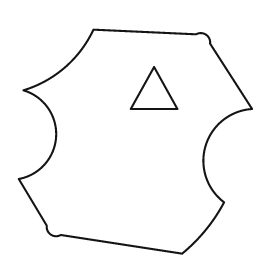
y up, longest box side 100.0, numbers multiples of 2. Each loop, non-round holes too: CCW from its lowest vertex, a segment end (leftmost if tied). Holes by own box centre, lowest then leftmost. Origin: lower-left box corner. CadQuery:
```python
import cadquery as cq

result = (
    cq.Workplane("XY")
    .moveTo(70.0, 0.0)
    .threePointArc((80.0, 10.0), (88.0, 22.0))
    .threePointArc((80.0, 46.0), (100.0, 62.0))
    .lineTo(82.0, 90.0)
    .threePointArc((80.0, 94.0), (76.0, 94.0))
    .lineTo(32.0, 96.0)
    .threePointArc((20.0, 80.0), (2.0, 70.0))
    .threePointArc((16.0, 50.0), (0.0, 32.0))
    .lineTo(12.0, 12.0)
    .threePointArc((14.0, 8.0), (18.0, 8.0))
    .close()
    .moveTo(48.0, 62.0)
    .lineTo(68.0, 62.0)
    .lineTo(58.0, 80.0)
    .close()
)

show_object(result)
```